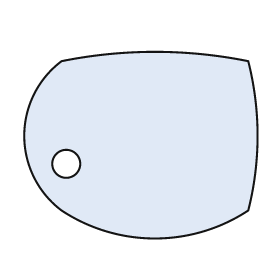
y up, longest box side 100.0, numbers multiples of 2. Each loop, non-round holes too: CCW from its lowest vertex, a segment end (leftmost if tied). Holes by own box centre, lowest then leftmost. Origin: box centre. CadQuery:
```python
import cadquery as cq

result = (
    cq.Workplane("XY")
    .moveTo(-34.0, -28.0)
    .threePointArc((6.0, -40.0), (46.0, -28.0))
    .threePointArc((50.0, 4.0), (46.0, 36.0))
    .threePointArc((6.0, 40.0), (-34.0, 36.0))
    .threePointArc((-50.0, 4.0), (-34.0, -28.0))
    .close()
    .moveTo(-32.0, -8.0)
    .circle(6.0)
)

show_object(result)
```